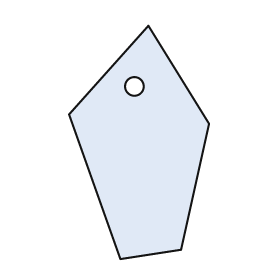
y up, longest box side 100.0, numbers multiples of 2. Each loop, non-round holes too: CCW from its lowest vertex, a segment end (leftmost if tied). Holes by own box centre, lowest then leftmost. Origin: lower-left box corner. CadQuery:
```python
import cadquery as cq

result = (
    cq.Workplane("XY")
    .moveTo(22.0, 0.0)
    .lineTo(48.0, 4.0)
    .lineTo(60.0, 58.0)
    .lineTo(34.0, 100.0)
    .lineTo(0.0, 62.0)
    .close()
    .moveTo(28.0, 74.0)
    .circle(4.0)
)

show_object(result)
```